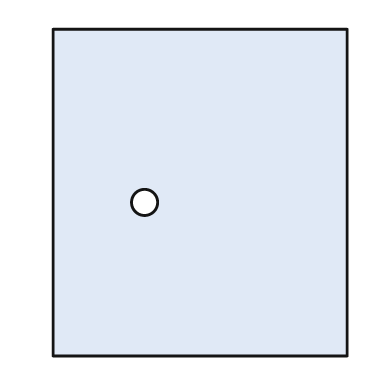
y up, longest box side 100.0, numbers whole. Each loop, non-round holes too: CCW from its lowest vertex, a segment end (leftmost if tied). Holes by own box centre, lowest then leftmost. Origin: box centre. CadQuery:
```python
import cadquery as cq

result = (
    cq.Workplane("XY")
    .moveTo(-45.0, -50.0)
    .lineTo(45.0, -50.0)
    .lineTo(45.0, 50.0)
    .lineTo(-45.0, 50.0)
    .close()
    .moveTo(-17.0, -3.0)
    .circle(4.0)
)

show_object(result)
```